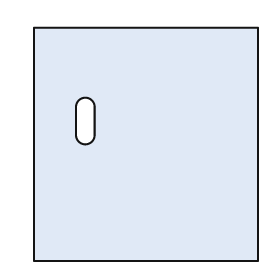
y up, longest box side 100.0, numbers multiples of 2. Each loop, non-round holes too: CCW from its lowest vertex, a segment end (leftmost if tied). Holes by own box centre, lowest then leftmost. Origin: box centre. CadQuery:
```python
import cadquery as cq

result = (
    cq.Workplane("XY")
    .moveTo(-48.0, -50.0)
    .lineTo(48.0, -50.0)
    .lineTo(48.0, 50.0)
    .lineTo(-48.0, 50.0)
    .close()
    .moveTo(-30.0, 4.0)
    .threePointArc((-26.0, 0.0), (-22.0, 4.0))
    .lineTo(-22.0, 16.0)
    .threePointArc((-26.0, 20.0), (-30.0, 16.0))
    .close()
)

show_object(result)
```